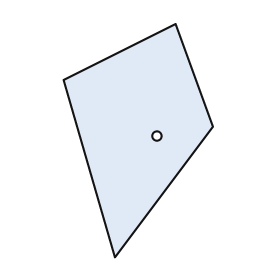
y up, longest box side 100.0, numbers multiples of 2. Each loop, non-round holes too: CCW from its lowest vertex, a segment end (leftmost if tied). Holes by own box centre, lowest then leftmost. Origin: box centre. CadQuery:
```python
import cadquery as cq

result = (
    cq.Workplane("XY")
    .moveTo(-10.0, -50.0)
    .lineTo(32.0, 6.0)
    .lineTo(16.0, 50.0)
    .lineTo(-32.0, 26.0)
    .close()
    .moveTo(8.0, 2.0)
    .circle(2.0)
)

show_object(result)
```